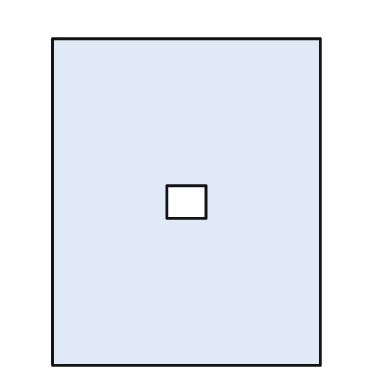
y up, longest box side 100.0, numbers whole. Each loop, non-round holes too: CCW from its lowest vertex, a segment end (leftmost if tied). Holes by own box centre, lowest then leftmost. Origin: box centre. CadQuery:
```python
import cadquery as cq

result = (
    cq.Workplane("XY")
    .moveTo(-41.0, -50.0)
    .lineTo(41.0, -50.0)
    .lineTo(41.0, 50.0)
    .lineTo(-41.0, 50.0)
    .close()
    .moveTo(-6.0, -5.0)
    .lineTo(6.0, -5.0)
    .lineTo(6.0, 5.0)
    .lineTo(-6.0, 5.0)
    .close()
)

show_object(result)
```